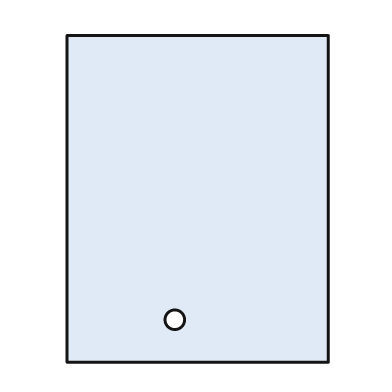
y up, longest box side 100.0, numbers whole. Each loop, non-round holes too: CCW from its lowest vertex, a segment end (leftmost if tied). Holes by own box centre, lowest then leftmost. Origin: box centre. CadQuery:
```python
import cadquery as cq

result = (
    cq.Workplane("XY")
    .moveTo(-40.0, -50.0)
    .lineTo(40.0, -50.0)
    .lineTo(40.0, 50.0)
    .lineTo(-40.0, 50.0)
    .close()
    .moveTo(-7.0, -37.0)
    .circle(3.0)
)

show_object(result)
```